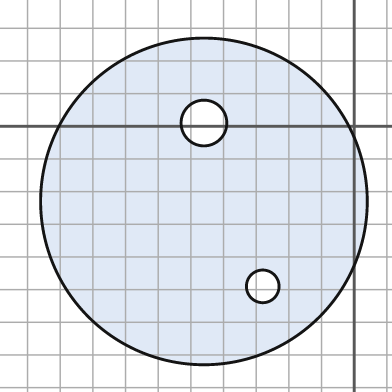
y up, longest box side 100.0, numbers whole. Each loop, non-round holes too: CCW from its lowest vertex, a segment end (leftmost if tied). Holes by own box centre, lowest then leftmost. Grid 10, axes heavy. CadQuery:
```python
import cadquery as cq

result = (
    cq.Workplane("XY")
    .moveTo(-46.0, -23.0)
    .circle(50.0)
    .moveTo(-28.0, -49.0)
    .circle(5.0)
    .moveTo(-46.0, 1.0)
    .circle(7.0)
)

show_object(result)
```